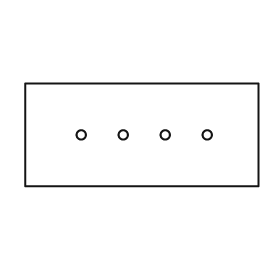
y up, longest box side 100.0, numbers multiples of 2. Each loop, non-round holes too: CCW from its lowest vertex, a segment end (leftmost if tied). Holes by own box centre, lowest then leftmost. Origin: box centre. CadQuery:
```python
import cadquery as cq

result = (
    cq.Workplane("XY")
    .moveTo(-50.0, -22.0)
    .lineTo(50.0, -22.0)
    .lineTo(50.0, 22.0)
    .lineTo(-50.0, 22.0)
    .close()
    .moveTo(-26.0, 0.0)
    .circle(2.0)
    .moveTo(-8.0, 0.0)
    .circle(2.0)
    .moveTo(10.0, 0.0)
    .circle(2.0)
    .moveTo(28.0, 0.0)
    .circle(2.0)
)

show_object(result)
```